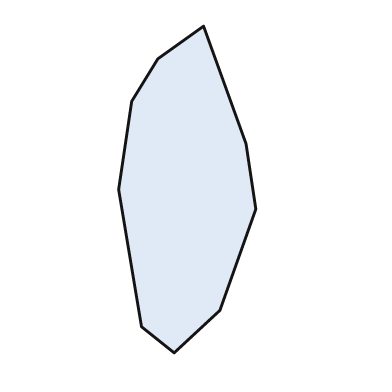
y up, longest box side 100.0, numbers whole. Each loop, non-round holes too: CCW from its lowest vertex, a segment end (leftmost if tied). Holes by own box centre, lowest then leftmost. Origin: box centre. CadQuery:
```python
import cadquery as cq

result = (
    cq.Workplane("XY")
    .moveTo(-4.0, -50.0)
    .lineTo(10.0, -37.0)
    .lineTo(21.0, -6.0)
    .lineTo(18.0, 14.0)
    .lineTo(5.0, 50.0)
    .lineTo(-9.0, 40.0)
    .lineTo(-17.0, 27.0)
    .lineTo(-21.0, 0.0)
    .lineTo(-14.0, -42.0)
    .close()
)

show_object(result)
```